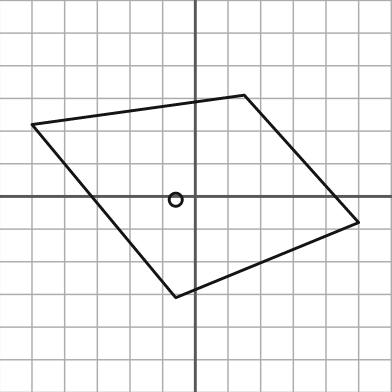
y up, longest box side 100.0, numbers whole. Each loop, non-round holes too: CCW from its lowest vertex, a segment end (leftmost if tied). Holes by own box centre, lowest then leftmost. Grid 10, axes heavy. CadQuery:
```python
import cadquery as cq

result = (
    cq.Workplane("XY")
    .moveTo(-6.0, -31.0)
    .lineTo(50.0, -8.0)
    .lineTo(15.0, 31.0)
    .lineTo(-50.0, 22.0)
    .close()
    .moveTo(-6.0, -1.0)
    .circle(2.0)
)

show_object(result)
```